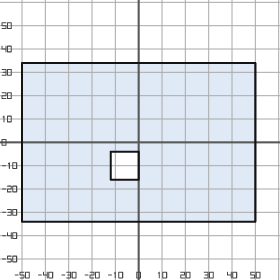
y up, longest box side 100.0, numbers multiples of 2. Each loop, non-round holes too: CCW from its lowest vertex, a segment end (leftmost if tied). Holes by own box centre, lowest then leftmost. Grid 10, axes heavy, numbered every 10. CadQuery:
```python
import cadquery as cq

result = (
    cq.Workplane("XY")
    .moveTo(-50.0, -34.0)
    .lineTo(50.0, -34.0)
    .lineTo(50.0, 34.0)
    .lineTo(-50.0, 34.0)
    .close()
    .moveTo(-12.0, -16.0)
    .lineTo(0.0, -16.0)
    .lineTo(0.0, -4.0)
    .lineTo(-12.0, -4.0)
    .close()
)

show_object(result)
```